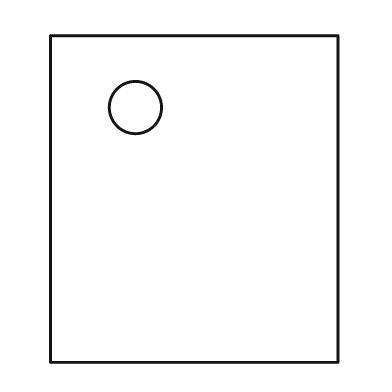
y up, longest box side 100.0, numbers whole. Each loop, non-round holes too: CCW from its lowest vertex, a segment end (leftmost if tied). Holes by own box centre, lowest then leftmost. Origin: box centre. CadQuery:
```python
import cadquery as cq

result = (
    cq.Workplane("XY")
    .moveTo(-44.0, -50.0)
    .lineTo(44.0, -50.0)
    .lineTo(44.0, 50.0)
    .lineTo(-44.0, 50.0)
    .close()
    .moveTo(-18.0, 28.0)
    .circle(8.0)
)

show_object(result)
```